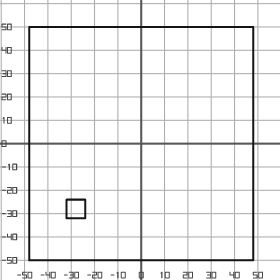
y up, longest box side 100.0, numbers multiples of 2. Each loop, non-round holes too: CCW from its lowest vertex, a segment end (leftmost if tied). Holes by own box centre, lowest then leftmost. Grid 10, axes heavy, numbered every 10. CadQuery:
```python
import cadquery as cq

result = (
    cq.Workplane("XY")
    .moveTo(-48.0, -50.0)
    .lineTo(48.0, -50.0)
    .lineTo(48.0, 50.0)
    .lineTo(-48.0, 50.0)
    .close()
    .moveTo(-32.0, -32.0)
    .lineTo(-24.0, -32.0)
    .lineTo(-24.0, -24.0)
    .lineTo(-32.0, -24.0)
    .close()
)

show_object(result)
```